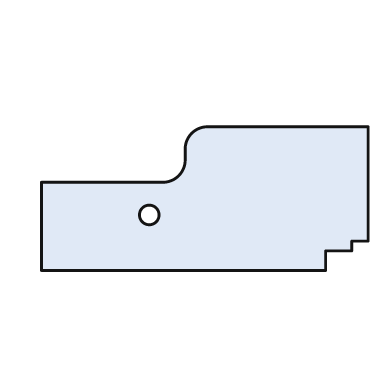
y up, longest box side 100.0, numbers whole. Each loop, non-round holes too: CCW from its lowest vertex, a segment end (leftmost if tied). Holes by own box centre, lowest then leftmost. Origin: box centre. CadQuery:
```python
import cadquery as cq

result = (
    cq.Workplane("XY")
    .moveTo(-50.0, -22.0)
    .lineTo(37.0, -22.0)
    .lineTo(37.0, -16.0)
    .lineTo(45.0, -16.0)
    .lineTo(45.0, -13.0)
    .lineTo(50.0, -13.0)
    .lineTo(50.0, 22.0)
    .lineTo(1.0, 22.0)
    .threePointArc((-4.0, 20.0), (-6.0, 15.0))
    .lineTo(-6.0, 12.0)
    .threePointArc((-8.0, 7.0), (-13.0, 5.0))
    .lineTo(-50.0, 5.0)
    .close()
    .moveTo(-17.0, -5.0)
    .circle(3.0)
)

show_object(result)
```